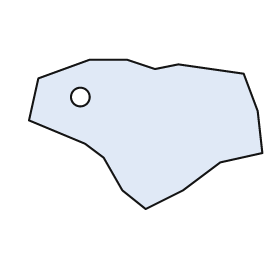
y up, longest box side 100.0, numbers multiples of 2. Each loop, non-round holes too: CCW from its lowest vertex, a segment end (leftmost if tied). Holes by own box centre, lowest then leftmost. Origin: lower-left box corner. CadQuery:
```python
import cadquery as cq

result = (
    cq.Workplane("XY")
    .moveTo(50.0, 0.0)
    .lineTo(66.0, 8.0)
    .lineTo(82.0, 20.0)
    .lineTo(100.0, 24.0)
    .lineTo(98.0, 42.0)
    .lineTo(92.0, 58.0)
    .lineTo(64.0, 62.0)
    .lineTo(54.0, 60.0)
    .lineTo(42.0, 64.0)
    .lineTo(26.0, 64.0)
    .lineTo(4.0, 56.0)
    .lineTo(0.0, 38.0)
    .lineTo(24.0, 28.0)
    .lineTo(32.0, 22.0)
    .lineTo(40.0, 8.0)
    .close()
    .moveTo(22.0, 48.0)
    .circle(4.0)
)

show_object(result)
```